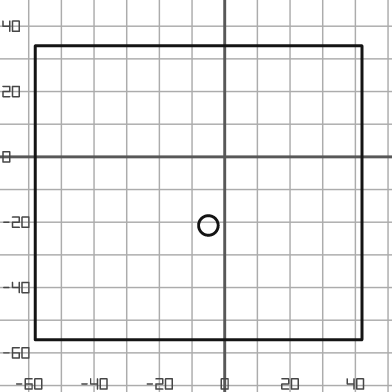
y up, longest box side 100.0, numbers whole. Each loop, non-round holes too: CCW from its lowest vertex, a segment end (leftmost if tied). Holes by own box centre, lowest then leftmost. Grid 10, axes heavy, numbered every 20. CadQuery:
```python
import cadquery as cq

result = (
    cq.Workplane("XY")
    .moveTo(-58.0, -56.0)
    .lineTo(42.0, -56.0)
    .lineTo(42.0, 34.0)
    .lineTo(-58.0, 34.0)
    .close()
    .moveTo(-5.0, -21.0)
    .circle(3.0)
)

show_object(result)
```